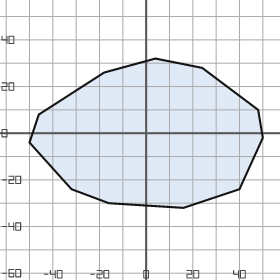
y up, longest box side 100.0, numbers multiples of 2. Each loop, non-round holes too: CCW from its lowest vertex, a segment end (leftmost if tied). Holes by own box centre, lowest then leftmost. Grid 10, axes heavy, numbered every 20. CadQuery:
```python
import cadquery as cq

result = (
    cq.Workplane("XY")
    .moveTo(16.0, -32.0)
    .lineTo(40.0, -24.0)
    .lineTo(50.0, -2.0)
    .lineTo(48.0, 10.0)
    .lineTo(24.0, 28.0)
    .lineTo(4.0, 32.0)
    .lineTo(-18.0, 26.0)
    .lineTo(-46.0, 8.0)
    .lineTo(-50.0, -4.0)
    .lineTo(-32.0, -24.0)
    .lineTo(-16.0, -30.0)
    .close()
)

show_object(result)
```